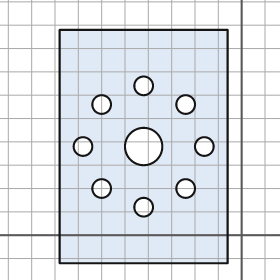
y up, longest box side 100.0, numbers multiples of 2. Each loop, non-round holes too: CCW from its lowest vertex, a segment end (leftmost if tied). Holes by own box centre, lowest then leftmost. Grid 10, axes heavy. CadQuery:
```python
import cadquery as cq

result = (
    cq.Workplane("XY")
    .moveTo(-78.0, -12.0)
    .lineTo(-6.0, -12.0)
    .lineTo(-6.0, 88.0)
    .lineTo(-78.0, 88.0)
    .close()
    .moveTo(-42.0, 12.0)
    .circle(4.0)
    .moveTo(-60.0, 20.0)
    .circle(4.0)
    .moveTo(-24.0, 20.0)
    .circle(4.0)
    .moveTo(-68.0, 38.0)
    .circle(4.0)
    .moveTo(-42.0, 38.0)
    .circle(8.0)
    .moveTo(-16.0, 38.0)
    .circle(4.0)
    .moveTo(-60.0, 56.0)
    .circle(4.0)
    .moveTo(-24.0, 56.0)
    .circle(4.0)
    .moveTo(-42.0, 64.0)
    .circle(4.0)
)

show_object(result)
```